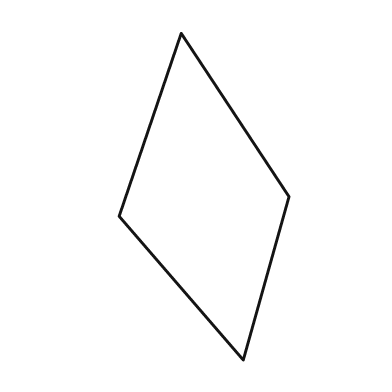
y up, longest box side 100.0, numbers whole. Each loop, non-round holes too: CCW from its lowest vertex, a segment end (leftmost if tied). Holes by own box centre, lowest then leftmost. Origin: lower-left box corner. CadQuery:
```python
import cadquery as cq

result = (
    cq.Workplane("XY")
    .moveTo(38.0, 0.0)
    .lineTo(52.0, 50.0)
    .lineTo(19.0, 100.0)
    .lineTo(0.0, 44.0)
    .close()
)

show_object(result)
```